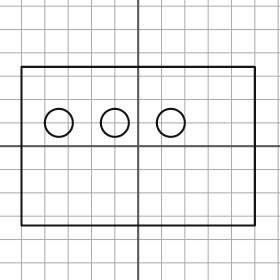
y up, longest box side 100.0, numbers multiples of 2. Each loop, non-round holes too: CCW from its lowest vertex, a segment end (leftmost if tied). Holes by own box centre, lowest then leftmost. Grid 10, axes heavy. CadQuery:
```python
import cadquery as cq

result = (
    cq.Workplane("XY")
    .moveTo(-50.0, -34.0)
    .lineTo(50.0, -34.0)
    .lineTo(50.0, 34.0)
    .lineTo(-50.0, 34.0)
    .close()
    .moveTo(-34.0, 10.0)
    .circle(6.0)
    .moveTo(-10.0, 10.0)
    .circle(6.0)
    .moveTo(14.0, 10.0)
    .circle(6.0)
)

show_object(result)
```